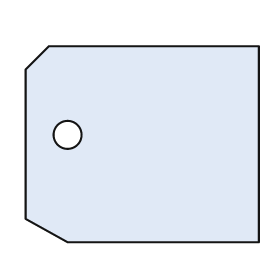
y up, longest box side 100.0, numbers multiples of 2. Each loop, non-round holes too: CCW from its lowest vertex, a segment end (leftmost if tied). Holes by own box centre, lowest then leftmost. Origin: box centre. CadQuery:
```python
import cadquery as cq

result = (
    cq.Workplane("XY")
    .moveTo(-32.0, -42.0)
    .lineTo(50.0, -42.0)
    .lineTo(50.0, 42.0)
    .lineTo(-40.0, 42.0)
    .lineTo(-50.0, 32.0)
    .lineTo(-50.0, -32.0)
    .close()
    .moveTo(-32.0, 4.0)
    .circle(6.0)
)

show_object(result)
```